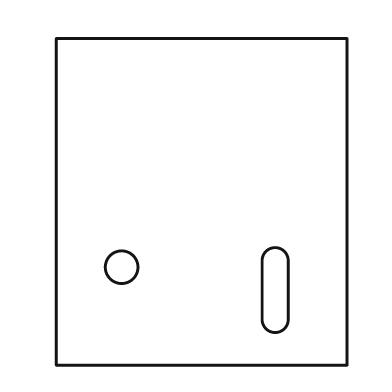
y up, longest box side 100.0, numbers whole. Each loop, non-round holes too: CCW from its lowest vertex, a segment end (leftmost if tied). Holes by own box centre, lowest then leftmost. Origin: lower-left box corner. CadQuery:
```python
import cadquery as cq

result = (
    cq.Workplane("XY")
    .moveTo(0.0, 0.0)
    .lineTo(89.0, 0.0)
    .lineTo(89.0, 100.0)
    .lineTo(0.0, 100.0)
    .close()
    .moveTo(63.0, 14.0)
    .threePointArc((67.0, 10.0), (71.0, 14.0))
    .lineTo(71.0, 32.0)
    .threePointArc((67.0, 36.0), (63.0, 32.0))
    .close()
    .moveTo(20.0, 30.0)
    .circle(5.0)
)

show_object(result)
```